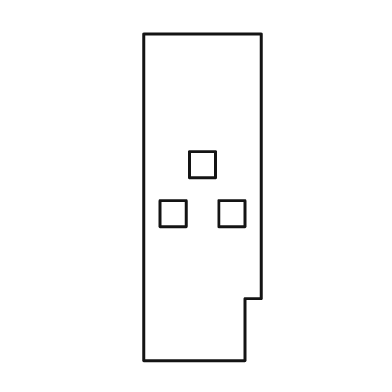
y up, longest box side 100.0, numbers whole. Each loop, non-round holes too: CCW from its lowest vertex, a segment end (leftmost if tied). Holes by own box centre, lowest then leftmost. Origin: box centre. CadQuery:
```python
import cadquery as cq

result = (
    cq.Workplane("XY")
    .moveTo(-18.0, -50.0)
    .lineTo(13.0, -50.0)
    .lineTo(13.0, -31.0)
    .lineTo(18.0, -31.0)
    .lineTo(18.0, 50.0)
    .lineTo(-18.0, 50.0)
    .close()
    .moveTo(-13.0, -9.0)
    .lineTo(-5.0, -9.0)
    .lineTo(-5.0, -1.0)
    .lineTo(-13.0, -1.0)
    .close()
    .moveTo(5.0, -9.0)
    .lineTo(13.0, -9.0)
    .lineTo(13.0, -1.0)
    .lineTo(5.0, -1.0)
    .close()
    .moveTo(-4.0, 6.0)
    .lineTo(4.0, 6.0)
    .lineTo(4.0, 14.0)
    .lineTo(-4.0, 14.0)
    .close()
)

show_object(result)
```